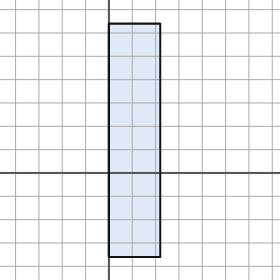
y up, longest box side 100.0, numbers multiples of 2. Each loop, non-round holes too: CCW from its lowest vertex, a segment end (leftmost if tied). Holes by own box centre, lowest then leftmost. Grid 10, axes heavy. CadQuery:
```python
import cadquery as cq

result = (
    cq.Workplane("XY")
    .moveTo(0.0, -36.0)
    .lineTo(22.0, -36.0)
    .lineTo(22.0, 64.0)
    .lineTo(0.0, 64.0)
    .close()
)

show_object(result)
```